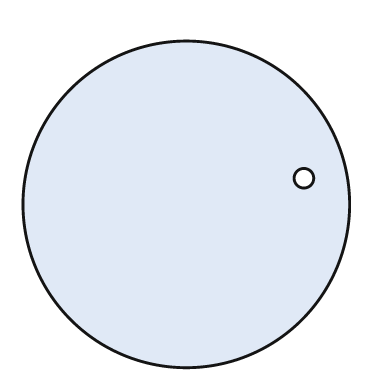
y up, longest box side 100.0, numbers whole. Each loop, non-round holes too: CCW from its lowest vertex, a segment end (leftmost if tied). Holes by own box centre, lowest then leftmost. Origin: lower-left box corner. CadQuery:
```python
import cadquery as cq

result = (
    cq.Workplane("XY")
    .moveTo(50.0, 50.0)
    .circle(50.0)
    .moveTo(86.0, 58.0)
    .circle(3.0)
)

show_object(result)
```